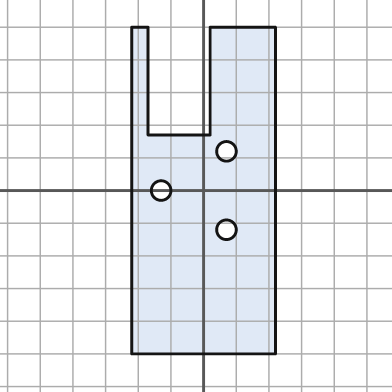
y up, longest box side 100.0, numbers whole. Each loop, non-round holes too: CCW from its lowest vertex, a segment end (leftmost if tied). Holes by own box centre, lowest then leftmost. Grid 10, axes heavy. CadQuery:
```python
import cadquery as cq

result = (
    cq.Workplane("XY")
    .moveTo(-22.0, -50.0)
    .lineTo(22.0, -50.0)
    .lineTo(22.0, 50.0)
    .lineTo(2.0, 50.0)
    .lineTo(2.0, 17.0)
    .lineTo(-17.0, 17.0)
    .lineTo(-17.0, 50.0)
    .lineTo(-22.0, 50.0)
    .close()
    .moveTo(7.0, -12.0)
    .circle(3.0)
    .moveTo(-13.0, 0.0)
    .circle(3.0)
    .moveTo(7.0, 12.0)
    .circle(3.0)
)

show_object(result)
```